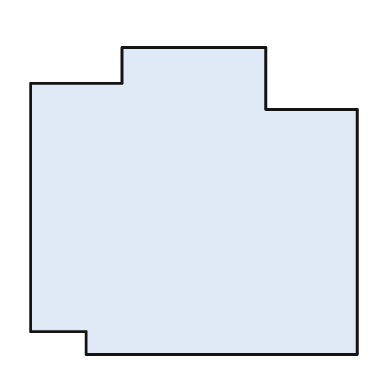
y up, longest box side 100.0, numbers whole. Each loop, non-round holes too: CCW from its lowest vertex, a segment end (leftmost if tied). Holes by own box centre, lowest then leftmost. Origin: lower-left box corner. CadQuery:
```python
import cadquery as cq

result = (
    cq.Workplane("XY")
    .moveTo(17.0, 0.0)
    .lineTo(100.0, 0.0)
    .lineTo(100.0, 75.0)
    .lineTo(72.0, 75.0)
    .lineTo(72.0, 94.0)
    .lineTo(28.0, 94.0)
    .lineTo(28.0, 83.0)
    .lineTo(0.0, 83.0)
    .lineTo(0.0, 7.0)
    .lineTo(17.0, 7.0)
    .close()
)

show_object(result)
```